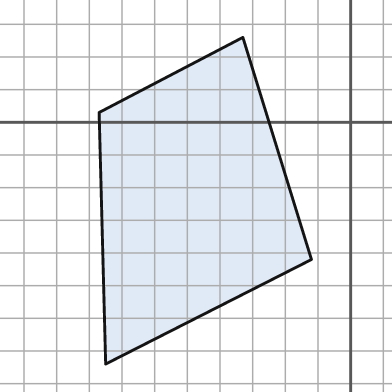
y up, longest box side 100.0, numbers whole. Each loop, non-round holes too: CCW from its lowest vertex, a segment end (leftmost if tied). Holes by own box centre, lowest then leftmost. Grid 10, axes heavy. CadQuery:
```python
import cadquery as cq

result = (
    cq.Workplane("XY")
    .moveTo(-75.0, -74.0)
    .lineTo(-12.0, -42.0)
    .lineTo(-33.0, 26.0)
    .lineTo(-77.0, 3.0)
    .close()
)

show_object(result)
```